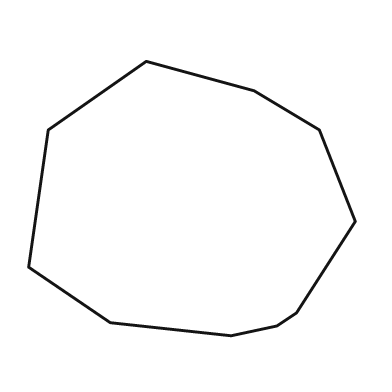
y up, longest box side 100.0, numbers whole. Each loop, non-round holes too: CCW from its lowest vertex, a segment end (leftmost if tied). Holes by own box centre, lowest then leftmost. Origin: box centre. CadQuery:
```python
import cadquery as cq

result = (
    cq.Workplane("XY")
    .moveTo(12.0, -42.0)
    .lineTo(26.0, -39.0)
    .lineTo(32.0, -35.0)
    .lineTo(50.0, -7.0)
    .lineTo(39.0, 21.0)
    .lineTo(19.0, 33.0)
    .lineTo(-14.0, 42.0)
    .lineTo(-44.0, 21.0)
    .lineTo(-50.0, -21.0)
    .lineTo(-25.0, -38.0)
    .close()
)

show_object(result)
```